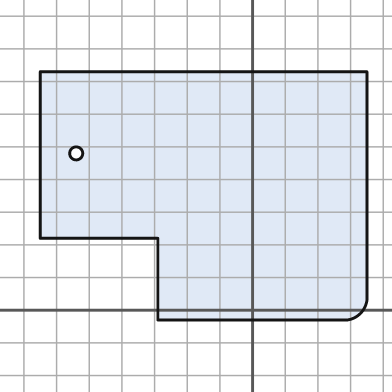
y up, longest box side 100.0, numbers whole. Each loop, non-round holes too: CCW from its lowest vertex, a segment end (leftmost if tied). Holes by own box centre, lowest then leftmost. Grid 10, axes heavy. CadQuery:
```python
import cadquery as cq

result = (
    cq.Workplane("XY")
    .moveTo(-29.0, -3.0)
    .lineTo(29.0, -3.0)
    .threePointArc((33.0, -1.0), (35.0, 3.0))
    .lineTo(35.0, 73.0)
    .lineTo(-65.0, 73.0)
    .lineTo(-65.0, 22.0)
    .lineTo(-29.0, 22.0)
    .close()
    .moveTo(-54.0, 48.0)
    .circle(2.0)
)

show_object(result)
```